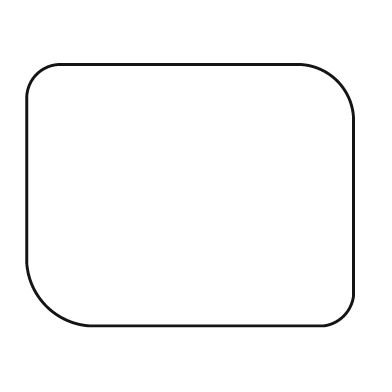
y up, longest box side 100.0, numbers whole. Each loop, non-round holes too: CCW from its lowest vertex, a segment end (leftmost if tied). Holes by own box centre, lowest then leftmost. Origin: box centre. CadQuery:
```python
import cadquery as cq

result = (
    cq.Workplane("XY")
    .moveTo(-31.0, -40.0)
    .lineTo(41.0, -40.0)
    .threePointArc((47.0, -37.0), (50.0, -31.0))
    .lineTo(50.0, 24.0)
    .threePointArc((45.0, 35.0), (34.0, 40.0))
    .lineTo(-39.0, 40.0)
    .threePointArc((-47.0, 37.0), (-50.0, 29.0))
    .lineTo(-50.0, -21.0)
    .threePointArc((-44.0, -34.0), (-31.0, -40.0))
    .close()
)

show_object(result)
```